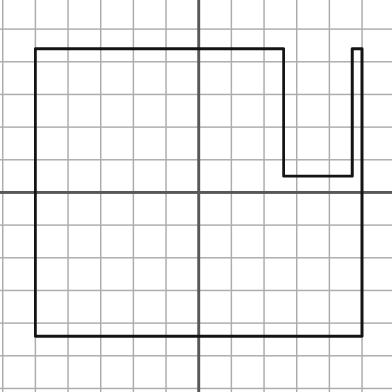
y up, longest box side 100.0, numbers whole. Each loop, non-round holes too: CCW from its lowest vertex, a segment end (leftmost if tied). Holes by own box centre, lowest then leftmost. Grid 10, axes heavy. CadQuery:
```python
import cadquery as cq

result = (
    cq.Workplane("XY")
    .moveTo(-50.0, -44.0)
    .lineTo(50.0, -44.0)
    .lineTo(50.0, 44.0)
    .lineTo(47.0, 44.0)
    .lineTo(47.0, 5.0)
    .lineTo(26.0, 5.0)
    .lineTo(26.0, 44.0)
    .lineTo(-50.0, 44.0)
    .close()
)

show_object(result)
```